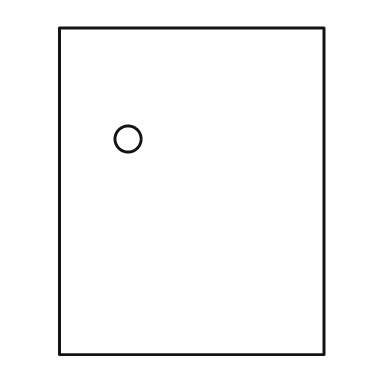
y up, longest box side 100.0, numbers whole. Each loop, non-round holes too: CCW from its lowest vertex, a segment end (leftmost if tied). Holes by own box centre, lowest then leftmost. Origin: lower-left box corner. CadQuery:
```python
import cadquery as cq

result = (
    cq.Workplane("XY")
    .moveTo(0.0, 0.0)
    .lineTo(81.0, 0.0)
    .lineTo(81.0, 100.0)
    .lineTo(0.0, 100.0)
    .close()
    .moveTo(21.0, 66.0)
    .circle(4.0)
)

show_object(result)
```